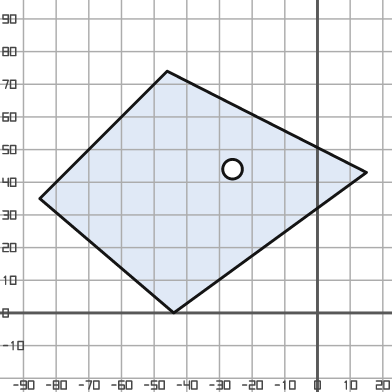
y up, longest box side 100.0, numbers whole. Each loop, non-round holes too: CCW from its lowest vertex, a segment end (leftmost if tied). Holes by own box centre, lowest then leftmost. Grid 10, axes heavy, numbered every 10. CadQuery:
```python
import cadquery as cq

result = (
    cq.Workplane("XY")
    .moveTo(-44.0, 0.0)
    .lineTo(15.0, 43.0)
    .lineTo(-46.0, 74.0)
    .lineTo(-85.0, 35.0)
    .close()
    .moveTo(-26.0, 44.0)
    .circle(3.0)
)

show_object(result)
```